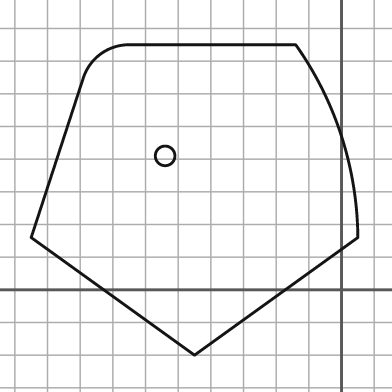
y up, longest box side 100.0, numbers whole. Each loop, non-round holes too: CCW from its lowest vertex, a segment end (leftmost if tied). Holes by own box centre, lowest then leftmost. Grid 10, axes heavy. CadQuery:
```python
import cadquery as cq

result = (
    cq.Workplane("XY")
    .moveTo(-45.0, -20.0)
    .lineTo(5.0, 16.0)
    .threePointArc((0.0, 47.0), (-14.0, 75.0))
    .lineTo(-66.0, 75.0)
    .threePointArc((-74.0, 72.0), (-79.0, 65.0))
    .lineTo(-95.0, 16.0)
    .close()
    .moveTo(-54.0, 41.0)
    .circle(3.0)
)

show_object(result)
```